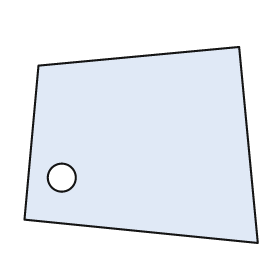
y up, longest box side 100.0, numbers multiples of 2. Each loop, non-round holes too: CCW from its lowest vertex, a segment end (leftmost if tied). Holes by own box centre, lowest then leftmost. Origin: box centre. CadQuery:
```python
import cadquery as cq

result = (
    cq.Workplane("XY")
    .moveTo(50.0, -42.0)
    .lineTo(42.0, 42.0)
    .lineTo(-44.0, 34.0)
    .lineTo(-50.0, -32.0)
    .close()
    .moveTo(-34.0, -14.0)
    .circle(6.0)
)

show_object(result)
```